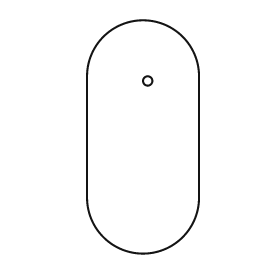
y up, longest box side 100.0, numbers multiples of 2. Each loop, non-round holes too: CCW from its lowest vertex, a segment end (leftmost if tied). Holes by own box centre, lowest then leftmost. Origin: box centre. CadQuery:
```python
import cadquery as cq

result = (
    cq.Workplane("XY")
    .moveTo(-24.0, -26.0)
    .threePointArc((0.0, -50.0), (24.0, -26.0))
    .lineTo(24.0, 26.0)
    .threePointArc((0.0, 50.0), (-24.0, 26.0))
    .close()
    .moveTo(2.0, 24.0)
    .circle(2.0)
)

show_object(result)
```